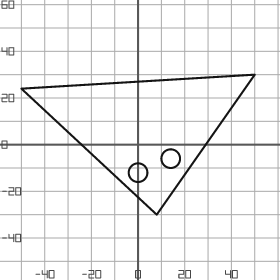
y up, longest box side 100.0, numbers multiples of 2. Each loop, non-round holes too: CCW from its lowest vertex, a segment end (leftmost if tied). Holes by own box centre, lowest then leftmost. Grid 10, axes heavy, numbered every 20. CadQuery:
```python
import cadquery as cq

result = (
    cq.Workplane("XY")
    .moveTo(8.0, -30.0)
    .lineTo(50.0, 30.0)
    .lineTo(-50.0, 24.0)
    .close()
    .moveTo(0.0, -12.0)
    .circle(4.0)
    .moveTo(14.0, -6.0)
    .circle(4.0)
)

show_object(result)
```